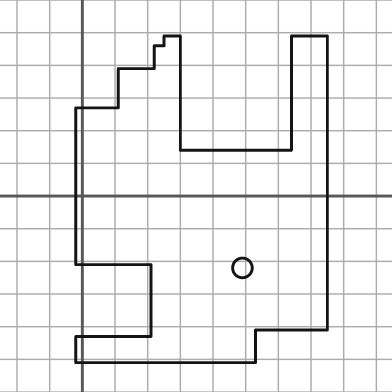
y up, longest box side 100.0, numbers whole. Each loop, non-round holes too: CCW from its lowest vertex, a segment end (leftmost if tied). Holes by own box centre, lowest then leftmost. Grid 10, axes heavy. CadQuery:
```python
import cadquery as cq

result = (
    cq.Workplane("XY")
    .moveTo(-2.0, -51.0)
    .lineTo(53.0, -51.0)
    .lineTo(53.0, -41.0)
    .lineTo(75.0, -41.0)
    .lineTo(75.0, 49.0)
    .lineTo(64.0, 49.0)
    .lineTo(64.0, 14.0)
    .lineTo(30.0, 14.0)
    .lineTo(30.0, 49.0)
    .lineTo(25.0, 49.0)
    .lineTo(25.0, 46.0)
    .lineTo(22.0, 46.0)
    .lineTo(22.0, 39.0)
    .lineTo(11.0, 39.0)
    .lineTo(11.0, 27.0)
    .lineTo(-2.0, 27.0)
    .lineTo(-2.0, -21.0)
    .lineTo(21.0, -21.0)
    .lineTo(21.0, -43.0)
    .lineTo(-2.0, -43.0)
    .close()
    .moveTo(49.0, -22.0)
    .circle(3.0)
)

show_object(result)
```